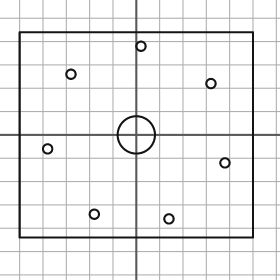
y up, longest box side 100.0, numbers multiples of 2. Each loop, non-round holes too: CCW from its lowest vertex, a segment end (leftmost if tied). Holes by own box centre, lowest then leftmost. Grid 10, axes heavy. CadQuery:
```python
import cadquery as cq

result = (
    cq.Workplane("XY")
    .moveTo(-50.0, -44.0)
    .lineTo(50.0, -44.0)
    .lineTo(50.0, 44.0)
    .lineTo(-50.0, 44.0)
    .close()
    .moveTo(14.0, -36.0)
    .circle(2.0)
    .moveTo(-18.0, -34.0)
    .circle(2.0)
    .moveTo(38.0, -12.0)
    .circle(2.0)
    .moveTo(-38.0, -6.0)
    .circle(2.0)
    .moveTo(0.0, 0.0)
    .circle(8.0)
    .moveTo(32.0, 22.0)
    .circle(2.0)
    .moveTo(-28.0, 26.0)
    .circle(2.0)
    .moveTo(2.0, 38.0)
    .circle(2.0)
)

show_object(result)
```